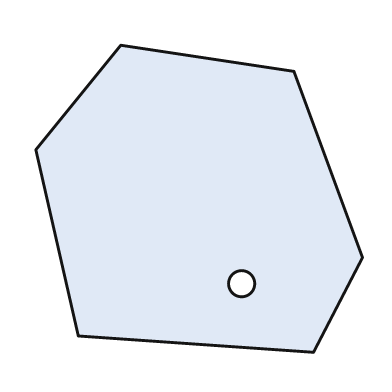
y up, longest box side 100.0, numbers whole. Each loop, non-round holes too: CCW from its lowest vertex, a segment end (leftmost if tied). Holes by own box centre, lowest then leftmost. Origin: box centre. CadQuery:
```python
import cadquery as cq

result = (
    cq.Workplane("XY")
    .moveTo(35.0, -47.0)
    .lineTo(50.0, -18.0)
    .lineTo(29.0, 39.0)
    .lineTo(-24.0, 47.0)
    .lineTo(-50.0, 15.0)
    .lineTo(-37.0, -42.0)
    .close()
    .moveTo(13.0, -26.0)
    .circle(4.0)
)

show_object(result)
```